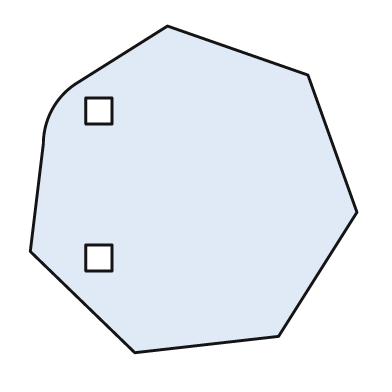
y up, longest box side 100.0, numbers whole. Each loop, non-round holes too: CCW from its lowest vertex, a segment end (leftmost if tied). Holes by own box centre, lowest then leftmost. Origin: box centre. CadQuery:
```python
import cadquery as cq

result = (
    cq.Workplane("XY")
    .moveTo(-18.0, -50.0)
    .lineTo(26.0, -45.0)
    .lineTo(50.0, -7.0)
    .lineTo(35.0, 35.0)
    .lineTo(-8.0, 50.0)
    .lineTo(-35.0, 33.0)
    .threePointArc((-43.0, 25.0), (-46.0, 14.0))
    .lineTo(-50.0, -19.0)
    .close()
    .moveTo(-33.0, -25.0)
    .lineTo(-25.0, -25.0)
    .lineTo(-25.0, -17.0)
    .lineTo(-33.0, -17.0)
    .close()
    .moveTo(-33.0, 20.0)
    .lineTo(-25.0, 20.0)
    .lineTo(-25.0, 28.0)
    .lineTo(-33.0, 28.0)
    .close()
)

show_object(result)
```